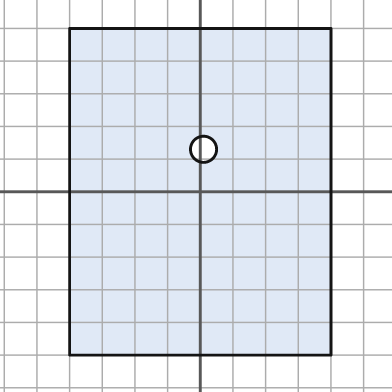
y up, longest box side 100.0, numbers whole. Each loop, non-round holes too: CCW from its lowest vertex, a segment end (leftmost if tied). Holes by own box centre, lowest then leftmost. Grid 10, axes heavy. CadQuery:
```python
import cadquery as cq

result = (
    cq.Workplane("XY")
    .moveTo(-40.0, -50.0)
    .lineTo(40.0, -50.0)
    .lineTo(40.0, 50.0)
    .lineTo(-40.0, 50.0)
    .close()
    .moveTo(1.0, 13.0)
    .circle(4.0)
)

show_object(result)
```